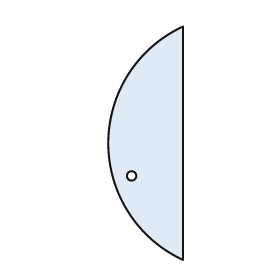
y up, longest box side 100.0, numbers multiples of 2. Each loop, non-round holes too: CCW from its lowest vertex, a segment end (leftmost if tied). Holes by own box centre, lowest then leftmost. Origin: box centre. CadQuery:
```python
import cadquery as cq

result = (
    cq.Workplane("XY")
    .moveTo(16.0, -50.0)
    .lineTo(16.0, 50.0)
    .threePointArc((-16.0, 0.0), (16.0, -50.0))
    .close()
    .moveTo(-6.0, -14.0)
    .circle(2.0)
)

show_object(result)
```